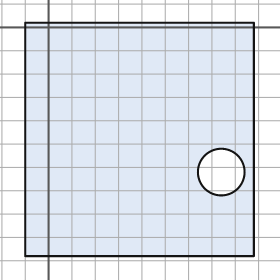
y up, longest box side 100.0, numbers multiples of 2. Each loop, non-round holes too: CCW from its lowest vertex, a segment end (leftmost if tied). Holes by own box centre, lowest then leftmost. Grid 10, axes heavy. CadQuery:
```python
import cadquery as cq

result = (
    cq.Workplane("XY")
    .moveTo(-10.0, -98.0)
    .lineTo(88.0, -98.0)
    .lineTo(88.0, 2.0)
    .lineTo(-10.0, 2.0)
    .close()
    .moveTo(74.0, -62.0)
    .circle(10.0)
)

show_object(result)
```